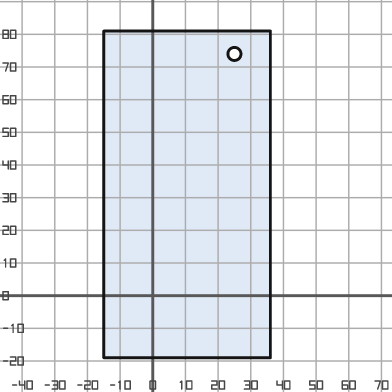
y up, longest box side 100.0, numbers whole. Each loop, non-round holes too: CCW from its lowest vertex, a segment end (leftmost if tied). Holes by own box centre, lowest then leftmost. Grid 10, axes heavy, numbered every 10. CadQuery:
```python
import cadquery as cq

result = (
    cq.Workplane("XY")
    .moveTo(-15.0, -19.0)
    .lineTo(36.0, -19.0)
    .lineTo(36.0, 81.0)
    .lineTo(-15.0, 81.0)
    .close()
    .moveTo(25.0, 74.0)
    .circle(2.0)
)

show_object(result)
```